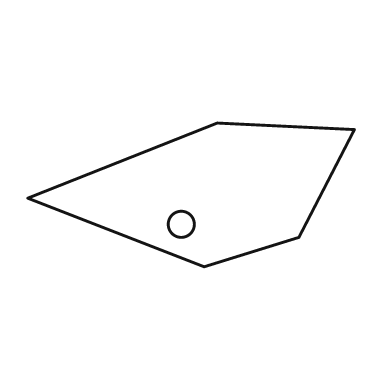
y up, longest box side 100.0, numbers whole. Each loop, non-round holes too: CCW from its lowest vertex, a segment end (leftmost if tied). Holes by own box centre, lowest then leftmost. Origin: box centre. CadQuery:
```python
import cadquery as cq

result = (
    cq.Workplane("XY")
    .moveTo(4.0, -22.0)
    .lineTo(33.0, -13.0)
    .lineTo(50.0, 20.0)
    .lineTo(8.0, 22.0)
    .lineTo(-50.0, -1.0)
    .close()
    .moveTo(-3.0, -9.0)
    .circle(4.0)
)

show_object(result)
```